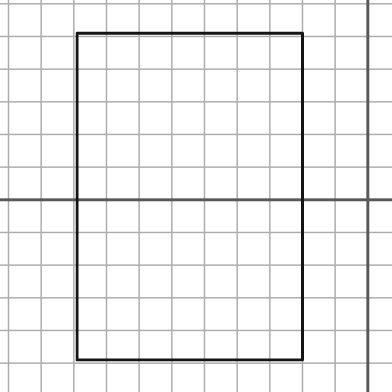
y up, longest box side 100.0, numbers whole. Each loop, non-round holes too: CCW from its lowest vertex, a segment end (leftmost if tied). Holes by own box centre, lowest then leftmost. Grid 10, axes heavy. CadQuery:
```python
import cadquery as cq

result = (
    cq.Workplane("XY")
    .moveTo(-89.0, -49.0)
    .lineTo(-20.0, -49.0)
    .lineTo(-20.0, 51.0)
    .lineTo(-89.0, 51.0)
    .close()
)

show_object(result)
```